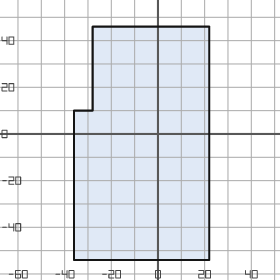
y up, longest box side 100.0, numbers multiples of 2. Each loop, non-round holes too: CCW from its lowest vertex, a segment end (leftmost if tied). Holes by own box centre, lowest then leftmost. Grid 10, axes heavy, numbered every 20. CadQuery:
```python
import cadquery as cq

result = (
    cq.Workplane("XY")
    .moveTo(-36.0, -54.0)
    .lineTo(22.0, -54.0)
    .lineTo(22.0, 46.0)
    .lineTo(-28.0, 46.0)
    .lineTo(-28.0, 10.0)
    .lineTo(-36.0, 10.0)
    .close()
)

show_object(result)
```